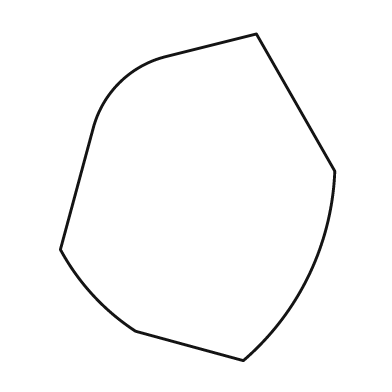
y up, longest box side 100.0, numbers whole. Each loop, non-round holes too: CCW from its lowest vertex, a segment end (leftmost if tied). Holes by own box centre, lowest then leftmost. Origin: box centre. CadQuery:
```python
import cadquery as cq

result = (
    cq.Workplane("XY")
    .moveTo(14.0, -50.0)
    .threePointArc((34.0, -24.0), (42.0, 8.0))
    .lineTo(18.0, 50.0)
    .lineTo(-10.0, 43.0)
    .threePointArc((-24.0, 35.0), (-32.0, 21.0))
    .lineTo(-42.0, -16.0)
    .threePointArc((-32.0, -30.0), (-19.0, -41.0))
    .close()
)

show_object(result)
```